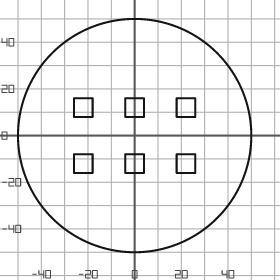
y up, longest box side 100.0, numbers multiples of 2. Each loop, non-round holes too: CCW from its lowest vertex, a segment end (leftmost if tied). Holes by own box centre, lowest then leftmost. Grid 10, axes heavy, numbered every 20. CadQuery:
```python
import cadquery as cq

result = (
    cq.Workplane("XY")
    .moveTo(0.0, 0.0)
    .circle(50.0)
    .moveTo(-26.0, -16.0)
    .lineTo(-18.0, -16.0)
    .lineTo(-18.0, -8.0)
    .lineTo(-26.0, -8.0)
    .close()
    .moveTo(-4.0, -16.0)
    .lineTo(4.0, -16.0)
    .lineTo(4.0, -8.0)
    .lineTo(-4.0, -8.0)
    .close()
    .moveTo(18.0, -16.0)
    .lineTo(26.0, -16.0)
    .lineTo(26.0, -8.0)
    .lineTo(18.0, -8.0)
    .close()
    .moveTo(-26.0, 8.0)
    .lineTo(-18.0, 8.0)
    .lineTo(-18.0, 16.0)
    .lineTo(-26.0, 16.0)
    .close()
    .moveTo(-4.0, 8.0)
    .lineTo(4.0, 8.0)
    .lineTo(4.0, 16.0)
    .lineTo(-4.0, 16.0)
    .close()
    .moveTo(18.0, 8.0)
    .lineTo(26.0, 8.0)
    .lineTo(26.0, 16.0)
    .lineTo(18.0, 16.0)
    .close()
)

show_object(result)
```